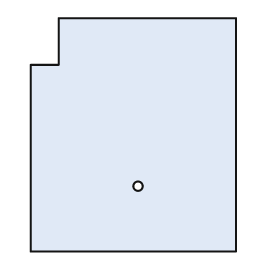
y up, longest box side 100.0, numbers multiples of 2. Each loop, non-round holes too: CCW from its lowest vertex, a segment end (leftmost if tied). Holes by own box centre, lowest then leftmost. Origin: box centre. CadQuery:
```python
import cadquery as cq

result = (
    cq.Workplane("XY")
    .moveTo(-44.0, -50.0)
    .lineTo(44.0, -50.0)
    .lineTo(44.0, 50.0)
    .lineTo(-32.0, 50.0)
    .lineTo(-32.0, 30.0)
    .lineTo(-44.0, 30.0)
    .close()
    .moveTo(2.0, -22.0)
    .circle(2.0)
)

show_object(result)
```